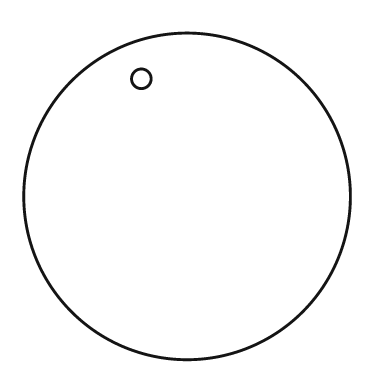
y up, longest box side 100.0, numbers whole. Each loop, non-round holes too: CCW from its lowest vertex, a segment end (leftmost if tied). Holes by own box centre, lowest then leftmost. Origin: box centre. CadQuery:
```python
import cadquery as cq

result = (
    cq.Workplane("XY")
    .moveTo(0.0, 0.0)
    .circle(50.0)
    .moveTo(-14.0, 36.0)
    .circle(3.0)
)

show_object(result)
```